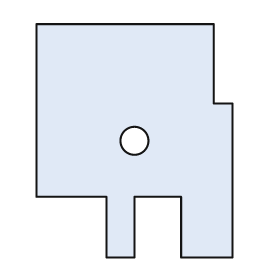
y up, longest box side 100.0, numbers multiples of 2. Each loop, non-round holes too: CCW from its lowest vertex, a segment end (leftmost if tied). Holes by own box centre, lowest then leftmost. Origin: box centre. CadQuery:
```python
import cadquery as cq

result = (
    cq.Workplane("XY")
    .moveTo(-12.0, -50.0)
    .lineTo(0.0, -50.0)
    .lineTo(0.0, -24.0)
    .lineTo(20.0, -24.0)
    .lineTo(20.0, -50.0)
    .lineTo(42.0, -50.0)
    .lineTo(42.0, 16.0)
    .lineTo(34.0, 16.0)
    .lineTo(34.0, 50.0)
    .lineTo(-42.0, 50.0)
    .lineTo(-42.0, -24.0)
    .lineTo(-12.0, -24.0)
    .close()
    .moveTo(0.0, 0.0)
    .circle(6.0)
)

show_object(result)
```